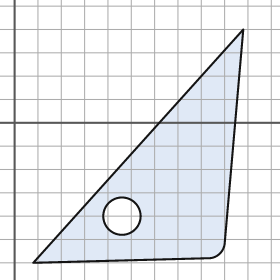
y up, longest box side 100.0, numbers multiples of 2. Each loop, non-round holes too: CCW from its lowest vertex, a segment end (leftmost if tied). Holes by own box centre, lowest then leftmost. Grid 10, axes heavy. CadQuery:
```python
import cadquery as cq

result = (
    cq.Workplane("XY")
    .moveTo(8.0, -60.0)
    .lineTo(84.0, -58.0)
    .threePointArc((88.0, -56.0), (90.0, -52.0))
    .lineTo(98.0, 40.0)
    .close()
    .moveTo(46.0, -40.0)
    .circle(8.0)
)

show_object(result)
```